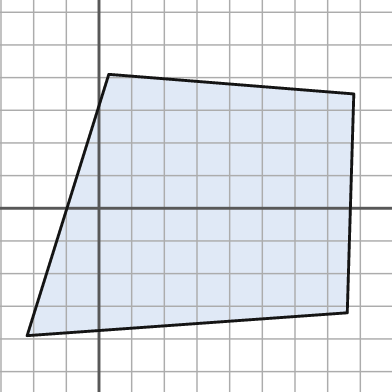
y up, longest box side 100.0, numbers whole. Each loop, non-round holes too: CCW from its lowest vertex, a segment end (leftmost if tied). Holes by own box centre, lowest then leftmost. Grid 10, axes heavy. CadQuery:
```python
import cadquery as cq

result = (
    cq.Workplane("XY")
    .moveTo(-22.0, -39.0)
    .lineTo(76.0, -32.0)
    .lineTo(78.0, 35.0)
    .lineTo(3.0, 41.0)
    .close()
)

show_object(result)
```